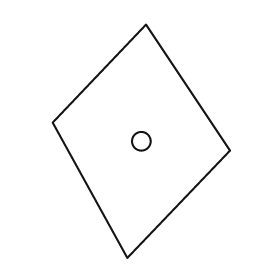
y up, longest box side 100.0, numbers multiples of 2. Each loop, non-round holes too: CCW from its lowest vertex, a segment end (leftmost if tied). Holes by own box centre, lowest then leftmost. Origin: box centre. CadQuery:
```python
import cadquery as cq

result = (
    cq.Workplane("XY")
    .moveTo(-6.0, -50.0)
    .lineTo(38.0, -4.0)
    .lineTo(2.0, 50.0)
    .lineTo(-38.0, 8.0)
    .close()
    .moveTo(0.0, 0.0)
    .circle(4.0)
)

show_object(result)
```